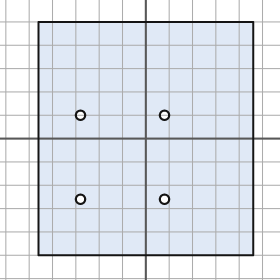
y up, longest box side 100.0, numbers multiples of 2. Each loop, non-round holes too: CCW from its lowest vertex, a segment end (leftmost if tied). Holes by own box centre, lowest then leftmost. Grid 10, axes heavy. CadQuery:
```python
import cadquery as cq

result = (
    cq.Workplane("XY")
    .moveTo(-46.0, -50.0)
    .lineTo(46.0, -50.0)
    .lineTo(46.0, 50.0)
    .lineTo(-46.0, 50.0)
    .close()
    .moveTo(-28.0, -26.0)
    .circle(2.0)
    .moveTo(8.0, -26.0)
    .circle(2.0)
    .moveTo(-28.0, 10.0)
    .circle(2.0)
    .moveTo(8.0, 10.0)
    .circle(2.0)
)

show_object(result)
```